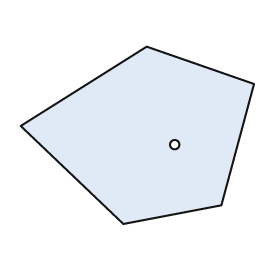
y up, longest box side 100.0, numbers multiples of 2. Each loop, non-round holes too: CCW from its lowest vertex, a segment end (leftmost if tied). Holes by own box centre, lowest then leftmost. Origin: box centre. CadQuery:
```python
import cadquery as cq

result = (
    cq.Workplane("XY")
    .moveTo(-6.0, -38.0)
    .lineTo(36.0, -30.0)
    .lineTo(50.0, 22.0)
    .lineTo(4.0, 38.0)
    .lineTo(-50.0, 4.0)
    .close()
    .moveTo(16.0, -4.0)
    .circle(2.0)
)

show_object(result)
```